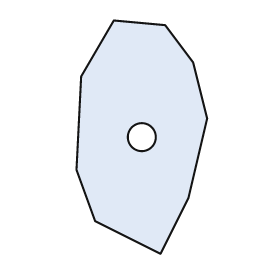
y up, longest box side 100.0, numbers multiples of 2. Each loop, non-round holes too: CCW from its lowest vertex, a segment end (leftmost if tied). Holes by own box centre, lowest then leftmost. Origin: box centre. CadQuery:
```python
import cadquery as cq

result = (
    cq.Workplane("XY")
    .moveTo(8.0, -50.0)
    .lineTo(20.0, -26.0)
    .lineTo(28.0, 8.0)
    .lineTo(22.0, 32.0)
    .lineTo(10.0, 48.0)
    .lineTo(-12.0, 50.0)
    .lineTo(-26.0, 26.0)
    .lineTo(-28.0, -14.0)
    .lineTo(-20.0, -36.0)
    .close()
    .moveTo(0.0, 0.0)
    .circle(6.0)
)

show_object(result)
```